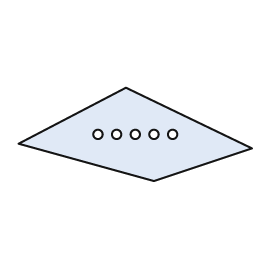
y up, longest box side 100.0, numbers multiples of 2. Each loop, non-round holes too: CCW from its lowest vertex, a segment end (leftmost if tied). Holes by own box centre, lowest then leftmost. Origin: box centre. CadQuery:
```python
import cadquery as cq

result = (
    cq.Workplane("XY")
    .moveTo(8.0, -20.0)
    .lineTo(50.0, -6.0)
    .lineTo(-4.0, 20.0)
    .lineTo(-50.0, -4.0)
    .close()
    .moveTo(-16.0, 0.0)
    .circle(2.0)
    .moveTo(-8.0, 0.0)
    .circle(2.0)
    .moveTo(0.0, 0.0)
    .circle(2.0)
    .moveTo(8.0, 0.0)
    .circle(2.0)
    .moveTo(16.0, 0.0)
    .circle(2.0)
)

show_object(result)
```